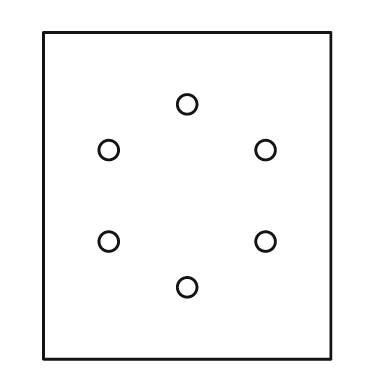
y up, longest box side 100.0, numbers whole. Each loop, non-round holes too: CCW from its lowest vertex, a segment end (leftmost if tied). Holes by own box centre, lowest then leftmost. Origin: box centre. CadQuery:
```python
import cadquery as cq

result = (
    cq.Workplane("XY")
    .moveTo(-44.0, -50.0)
    .lineTo(44.0, -50.0)
    .lineTo(44.0, 50.0)
    .lineTo(-44.0, 50.0)
    .close()
    .moveTo(0.0, -28.0)
    .circle(3.0)
    .moveTo(-24.0, -14.0)
    .circle(3.0)
    .moveTo(24.0, -14.0)
    .circle(3.0)
    .moveTo(-24.0, 14.0)
    .circle(3.0)
    .moveTo(24.0, 14.0)
    .circle(3.0)
    .moveTo(0.0, 28.0)
    .circle(3.0)
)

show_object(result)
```